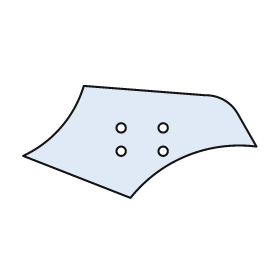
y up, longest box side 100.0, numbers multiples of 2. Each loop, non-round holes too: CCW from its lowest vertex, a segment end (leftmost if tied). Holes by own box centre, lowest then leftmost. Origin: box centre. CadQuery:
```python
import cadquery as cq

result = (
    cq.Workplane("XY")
    .moveTo(-4.0, -24.0)
    .threePointArc((20.0, -6.0), (50.0, -2.0))
    .lineTo(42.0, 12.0)
    .threePointArc((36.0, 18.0), (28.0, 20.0))
    .lineTo(-24.0, 24.0)
    .threePointArc((-34.0, 6.0), (-50.0, -6.0))
    .close()
    .moveTo(-8.0, -4.0)
    .circle(2.0)
    .moveTo(10.0, -4.0)
    .circle(2.0)
    .moveTo(-8.0, 6.0)
    .circle(2.0)
    .moveTo(10.0, 6.0)
    .circle(2.0)
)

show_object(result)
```